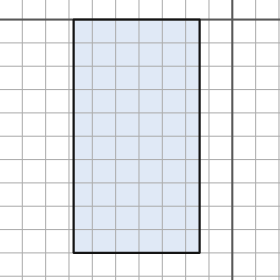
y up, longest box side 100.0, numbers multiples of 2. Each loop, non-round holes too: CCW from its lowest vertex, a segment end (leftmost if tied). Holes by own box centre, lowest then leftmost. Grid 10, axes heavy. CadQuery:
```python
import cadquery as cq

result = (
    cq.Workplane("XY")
    .moveTo(-68.0, -100.0)
    .lineTo(-14.0, -100.0)
    .lineTo(-14.0, 0.0)
    .lineTo(-68.0, 0.0)
    .close()
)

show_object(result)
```